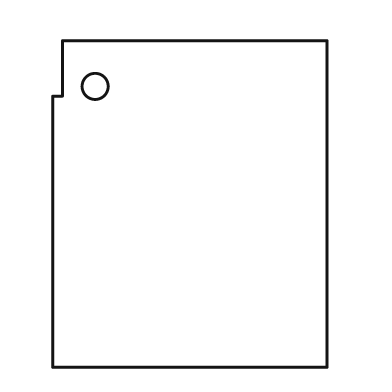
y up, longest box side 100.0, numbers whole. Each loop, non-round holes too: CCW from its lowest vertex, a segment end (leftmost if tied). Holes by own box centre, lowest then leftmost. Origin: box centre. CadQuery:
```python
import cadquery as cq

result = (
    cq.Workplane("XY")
    .moveTo(-42.0, -50.0)
    .lineTo(42.0, -50.0)
    .lineTo(42.0, 50.0)
    .lineTo(-39.0, 50.0)
    .lineTo(-39.0, 33.0)
    .lineTo(-42.0, 33.0)
    .close()
    .moveTo(-29.0, 36.0)
    .circle(4.0)
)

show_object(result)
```